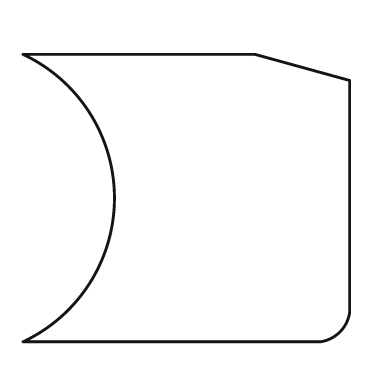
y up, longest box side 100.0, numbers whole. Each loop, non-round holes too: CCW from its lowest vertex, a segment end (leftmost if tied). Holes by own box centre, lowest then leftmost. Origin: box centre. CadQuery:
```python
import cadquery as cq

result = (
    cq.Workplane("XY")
    .moveTo(-50.0, -44.0)
    .lineTo(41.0, -44.0)
    .threePointArc((47.0, -41.0), (50.0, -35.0))
    .lineTo(50.0, 36.0)
    .lineTo(21.0, 44.0)
    .lineTo(-50.0, 44.0)
    .threePointArc((-22.0, 0.0), (-50.0, -44.0))
    .close()
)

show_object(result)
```